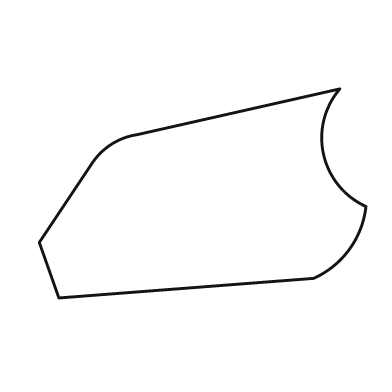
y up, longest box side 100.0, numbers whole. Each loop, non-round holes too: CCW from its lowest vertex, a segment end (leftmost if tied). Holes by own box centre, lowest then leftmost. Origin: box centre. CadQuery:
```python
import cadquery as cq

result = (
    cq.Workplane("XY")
    .moveTo(-44.0, -32.0)
    .lineTo(34.0, -26.0)
    .threePointArc((45.0, -17.0), (50.0, -4.0))
    .threePointArc((37.0, 12.0), (42.0, 32.0))
    .lineTo(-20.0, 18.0)
    .threePointArc((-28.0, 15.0), (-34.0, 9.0))
    .lineTo(-50.0, -15.0)
    .close()
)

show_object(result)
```